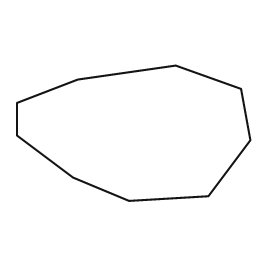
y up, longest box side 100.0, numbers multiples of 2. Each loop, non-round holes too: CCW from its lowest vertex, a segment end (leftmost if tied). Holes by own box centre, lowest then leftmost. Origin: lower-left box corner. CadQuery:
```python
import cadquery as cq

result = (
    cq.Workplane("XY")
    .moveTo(48.0, 0.0)
    .lineTo(82.0, 2.0)
    .lineTo(100.0, 26.0)
    .lineTo(96.0, 48.0)
    .lineTo(68.0, 58.0)
    .lineTo(26.0, 52.0)
    .lineTo(0.0, 42.0)
    .lineTo(0.0, 28.0)
    .lineTo(24.0, 10.0)
    .close()
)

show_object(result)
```